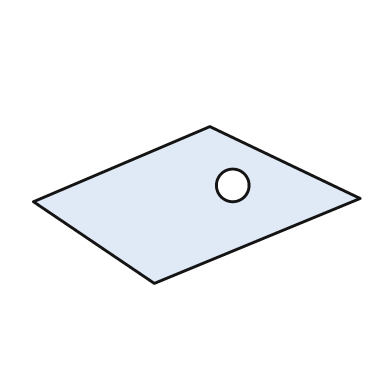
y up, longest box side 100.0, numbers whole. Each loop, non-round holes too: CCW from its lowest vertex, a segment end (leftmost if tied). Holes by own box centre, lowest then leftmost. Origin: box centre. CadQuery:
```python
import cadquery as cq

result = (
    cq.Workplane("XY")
    .moveTo(-13.0, -24.0)
    .lineTo(50.0, 2.0)
    .lineTo(4.0, 24.0)
    .lineTo(-50.0, 1.0)
    .close()
    .moveTo(11.0, 6.0)
    .circle(5.0)
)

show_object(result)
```